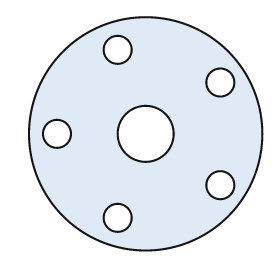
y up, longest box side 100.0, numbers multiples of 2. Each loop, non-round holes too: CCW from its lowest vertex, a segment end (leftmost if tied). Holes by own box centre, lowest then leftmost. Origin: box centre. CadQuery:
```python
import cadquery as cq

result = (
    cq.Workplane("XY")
    .moveTo(0.0, 0.0)
    .circle(50.0)
    .moveTo(-12.0, -36.0)
    .circle(6.0)
    .moveTo(32.0, -22.0)
    .circle(6.0)
    .moveTo(-38.0, 0.0)
    .circle(6.0)
    .moveTo(0.0, 0.0)
    .circle(12.0)
    .moveTo(32.0, 22.0)
    .circle(6.0)
    .moveTo(-12.0, 36.0)
    .circle(6.0)
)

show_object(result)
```